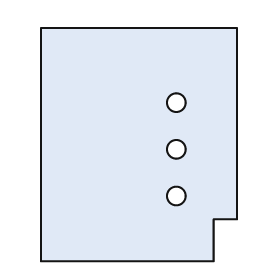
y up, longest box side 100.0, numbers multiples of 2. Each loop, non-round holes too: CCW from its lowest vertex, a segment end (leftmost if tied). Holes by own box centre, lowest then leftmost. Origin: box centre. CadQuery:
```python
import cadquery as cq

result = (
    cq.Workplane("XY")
    .moveTo(-42.0, -50.0)
    .lineTo(32.0, -50.0)
    .lineTo(32.0, -32.0)
    .lineTo(42.0, -32.0)
    .lineTo(42.0, 50.0)
    .lineTo(-42.0, 50.0)
    .close()
    .moveTo(16.0, -22.0)
    .circle(4.0)
    .moveTo(16.0, -2.0)
    .circle(4.0)
    .moveTo(16.0, 18.0)
    .circle(4.0)
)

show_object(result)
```